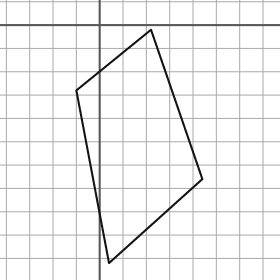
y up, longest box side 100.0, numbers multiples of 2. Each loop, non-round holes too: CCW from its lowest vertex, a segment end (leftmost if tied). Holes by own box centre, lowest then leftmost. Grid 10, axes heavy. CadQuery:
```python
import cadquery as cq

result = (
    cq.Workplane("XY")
    .moveTo(4.0, -102.0)
    .lineTo(44.0, -66.0)
    .lineTo(22.0, -2.0)
    .lineTo(-10.0, -28.0)
    .close()
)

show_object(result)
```